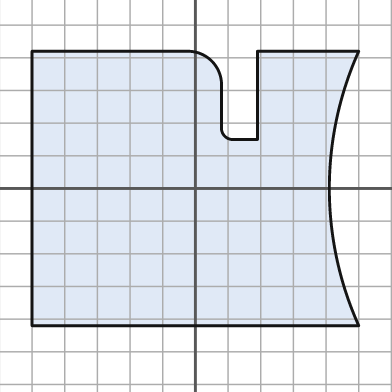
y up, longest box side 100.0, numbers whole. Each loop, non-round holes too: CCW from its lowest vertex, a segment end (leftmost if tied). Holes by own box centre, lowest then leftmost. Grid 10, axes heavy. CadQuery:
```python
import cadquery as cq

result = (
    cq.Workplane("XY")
    .moveTo(-50.0, -42.0)
    .lineTo(50.0, -42.0)
    .threePointArc((41.0, 0.0), (50.0, 42.0))
    .lineTo(19.0, 42.0)
    .lineTo(19.0, 15.0)
    .lineTo(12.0, 15.0)
    .threePointArc((9.0, 16.0), (8.0, 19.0))
    .lineTo(8.0, 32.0)
    .threePointArc((5.0, 39.0), (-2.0, 42.0))
    .lineTo(-50.0, 42.0)
    .close()
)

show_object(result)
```